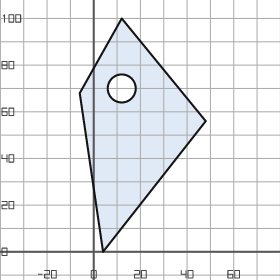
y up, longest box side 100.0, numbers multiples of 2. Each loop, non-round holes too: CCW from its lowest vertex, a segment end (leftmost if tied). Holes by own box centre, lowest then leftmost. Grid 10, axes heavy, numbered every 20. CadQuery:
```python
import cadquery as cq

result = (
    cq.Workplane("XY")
    .moveTo(4.0, 0.0)
    .lineTo(48.0, 56.0)
    .lineTo(12.0, 100.0)
    .lineTo(-6.0, 68.0)
    .close()
    .moveTo(12.0, 70.0)
    .circle(6.0)
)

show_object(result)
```